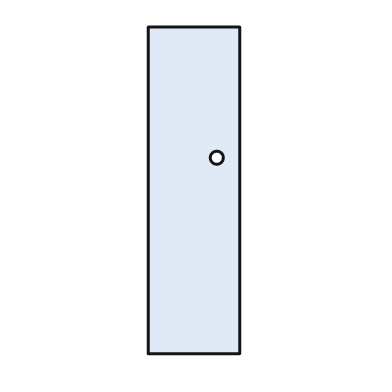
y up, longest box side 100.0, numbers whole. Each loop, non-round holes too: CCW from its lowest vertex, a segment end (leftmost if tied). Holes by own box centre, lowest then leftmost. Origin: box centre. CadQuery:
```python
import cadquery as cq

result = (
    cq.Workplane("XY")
    .moveTo(-14.0, -50.0)
    .lineTo(14.0, -50.0)
    .lineTo(14.0, 50.0)
    .lineTo(-14.0, 50.0)
    .close()
    .moveTo(7.0, 10.0)
    .circle(2.0)
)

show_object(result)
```